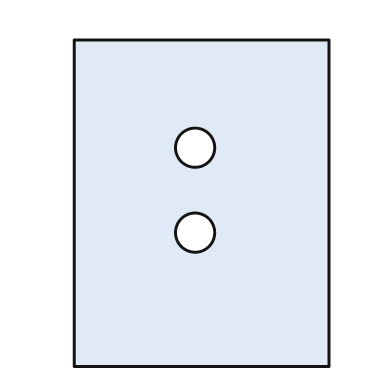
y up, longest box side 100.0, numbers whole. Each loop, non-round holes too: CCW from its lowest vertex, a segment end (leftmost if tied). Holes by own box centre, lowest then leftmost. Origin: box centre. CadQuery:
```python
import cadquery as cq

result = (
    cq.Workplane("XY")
    .moveTo(-39.0, -50.0)
    .lineTo(39.0, -50.0)
    .lineTo(39.0, 50.0)
    .lineTo(-39.0, 50.0)
    .close()
    .moveTo(-2.0, -9.0)
    .circle(6.0)
    .moveTo(-2.0, 17.0)
    .circle(6.0)
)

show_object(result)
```